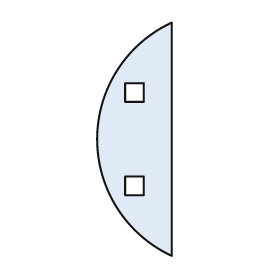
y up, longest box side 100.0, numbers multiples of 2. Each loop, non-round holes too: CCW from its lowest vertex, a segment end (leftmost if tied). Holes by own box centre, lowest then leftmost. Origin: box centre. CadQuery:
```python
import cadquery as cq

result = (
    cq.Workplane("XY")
    .moveTo(16.0, -50.0)
    .lineTo(16.0, 50.0)
    .threePointArc((-16.0, 0.0), (16.0, -50.0))
    .close()
    .moveTo(-4.0, -24.0)
    .lineTo(4.0, -24.0)
    .lineTo(4.0, -16.0)
    .lineTo(-4.0, -16.0)
    .close()
    .moveTo(-4.0, 16.0)
    .lineTo(4.0, 16.0)
    .lineTo(4.0, 24.0)
    .lineTo(-4.0, 24.0)
    .close()
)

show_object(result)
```